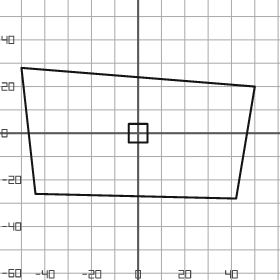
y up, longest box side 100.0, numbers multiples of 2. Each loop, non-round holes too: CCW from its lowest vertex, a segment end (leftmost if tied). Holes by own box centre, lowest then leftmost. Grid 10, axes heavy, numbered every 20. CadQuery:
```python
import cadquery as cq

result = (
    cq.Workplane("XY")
    .moveTo(42.0, -28.0)
    .lineTo(50.0, 20.0)
    .lineTo(-50.0, 28.0)
    .lineTo(-44.0, -26.0)
    .close()
    .moveTo(-4.0, -4.0)
    .lineTo(4.0, -4.0)
    .lineTo(4.0, 4.0)
    .lineTo(-4.0, 4.0)
    .close()
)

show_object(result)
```